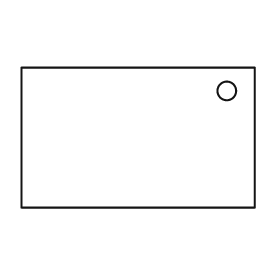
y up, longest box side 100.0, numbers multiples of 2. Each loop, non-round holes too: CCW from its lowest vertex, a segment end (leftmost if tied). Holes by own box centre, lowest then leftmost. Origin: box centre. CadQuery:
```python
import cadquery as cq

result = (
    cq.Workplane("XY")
    .moveTo(-50.0, -30.0)
    .lineTo(50.0, -30.0)
    .lineTo(50.0, 30.0)
    .lineTo(-50.0, 30.0)
    .close()
    .moveTo(38.0, 20.0)
    .circle(4.0)
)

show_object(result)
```